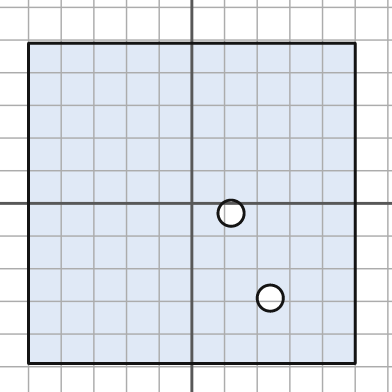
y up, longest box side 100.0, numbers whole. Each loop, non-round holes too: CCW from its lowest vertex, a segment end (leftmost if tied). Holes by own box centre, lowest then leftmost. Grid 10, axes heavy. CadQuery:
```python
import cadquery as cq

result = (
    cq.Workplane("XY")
    .moveTo(-50.0, -49.0)
    .lineTo(50.0, -49.0)
    .lineTo(50.0, 49.0)
    .lineTo(-50.0, 49.0)
    .close()
    .moveTo(24.0, -29.0)
    .circle(4.0)
    .moveTo(12.0, -3.0)
    .circle(4.0)
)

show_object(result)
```